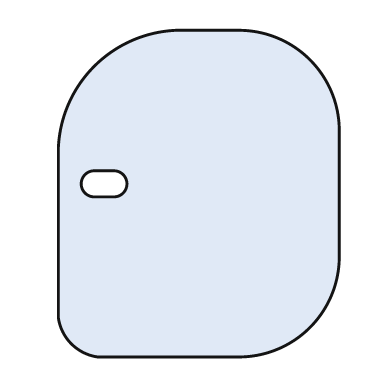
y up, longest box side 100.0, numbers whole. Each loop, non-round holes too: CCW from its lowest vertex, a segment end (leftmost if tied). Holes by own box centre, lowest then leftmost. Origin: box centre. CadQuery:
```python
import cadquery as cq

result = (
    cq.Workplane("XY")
    .moveTo(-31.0, -50.0)
    .lineTo(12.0, -50.0)
    .threePointArc((34.0, -41.0), (43.0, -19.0))
    .lineTo(43.0, 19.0)
    .threePointArc((34.0, 41.0), (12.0, 50.0))
    .lineTo(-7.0, 50.0)
    .threePointArc((-32.0, 39.0), (-43.0, 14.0))
    .lineTo(-43.0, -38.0)
    .threePointArc((-39.0, -46.0), (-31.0, -50.0))
    .close()
    .moveTo(-32.0, -1.0)
    .lineTo(-26.0, -1.0)
    .threePointArc((-22.0, 3.0), (-26.0, 7.0))
    .lineTo(-32.0, 7.0)
    .threePointArc((-36.0, 3.0), (-32.0, -1.0))
    .close()
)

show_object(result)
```